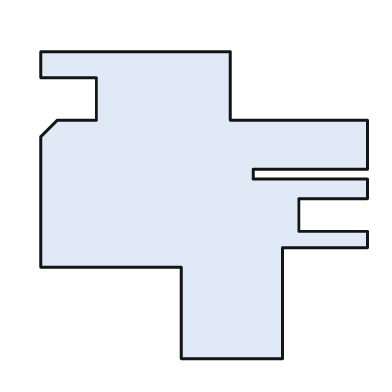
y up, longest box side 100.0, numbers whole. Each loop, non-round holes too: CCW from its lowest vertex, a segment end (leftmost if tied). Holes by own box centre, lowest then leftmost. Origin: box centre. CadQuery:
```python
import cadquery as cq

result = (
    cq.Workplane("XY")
    .moveTo(-7.0, -47.0)
    .lineTo(24.0, -47.0)
    .lineTo(24.0, -13.0)
    .lineTo(50.0, -13.0)
    .lineTo(50.0, -8.0)
    .lineTo(29.0, -8.0)
    .lineTo(29.0, 2.0)
    .lineTo(50.0, 2.0)
    .lineTo(50.0, 8.0)
    .lineTo(15.0, 8.0)
    .lineTo(15.0, 11.0)
    .lineTo(50.0, 11.0)
    .lineTo(50.0, 26.0)
    .lineTo(8.0, 26.0)
    .lineTo(8.0, 47.0)
    .lineTo(-50.0, 47.0)
    .lineTo(-50.0, 39.0)
    .lineTo(-33.0, 39.0)
    .lineTo(-33.0, 26.0)
    .lineTo(-45.0, 26.0)
    .lineTo(-50.0, 21.0)
    .lineTo(-50.0, -19.0)
    .lineTo(-7.0, -19.0)
    .close()
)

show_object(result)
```